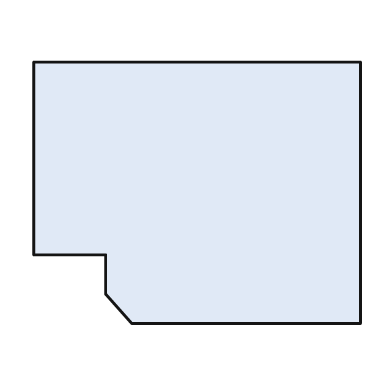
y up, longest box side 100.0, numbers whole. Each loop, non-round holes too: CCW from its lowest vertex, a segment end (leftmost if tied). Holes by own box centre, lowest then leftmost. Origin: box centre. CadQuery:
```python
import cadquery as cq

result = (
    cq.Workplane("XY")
    .moveTo(-20.0, -40.0)
    .lineTo(50.0, -40.0)
    .lineTo(50.0, 40.0)
    .lineTo(-50.0, 40.0)
    .lineTo(-50.0, -19.0)
    .lineTo(-28.0, -19.0)
    .lineTo(-28.0, -31.0)
    .close()
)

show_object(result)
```